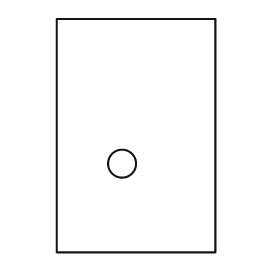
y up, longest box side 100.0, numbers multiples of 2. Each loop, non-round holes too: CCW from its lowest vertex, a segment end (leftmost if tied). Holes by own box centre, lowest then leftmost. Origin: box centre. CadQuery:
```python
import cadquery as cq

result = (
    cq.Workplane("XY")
    .moveTo(-34.0, -50.0)
    .lineTo(34.0, -50.0)
    .lineTo(34.0, 50.0)
    .lineTo(-34.0, 50.0)
    .close()
    .moveTo(-6.0, -12.0)
    .circle(6.0)
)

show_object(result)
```